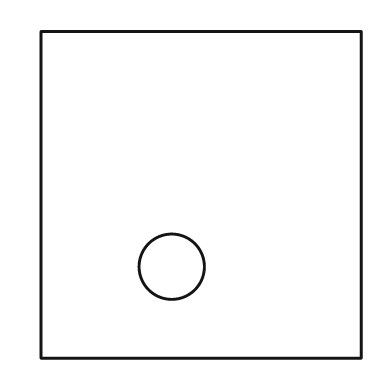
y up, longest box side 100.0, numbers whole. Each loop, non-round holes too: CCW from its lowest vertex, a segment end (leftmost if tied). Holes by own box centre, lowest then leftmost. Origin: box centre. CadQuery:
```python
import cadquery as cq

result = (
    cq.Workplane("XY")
    .moveTo(-49.0, -50.0)
    .lineTo(49.0, -50.0)
    .lineTo(49.0, 50.0)
    .lineTo(-49.0, 50.0)
    .close()
    .moveTo(-9.0, -22.0)
    .circle(10.0)
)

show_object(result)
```